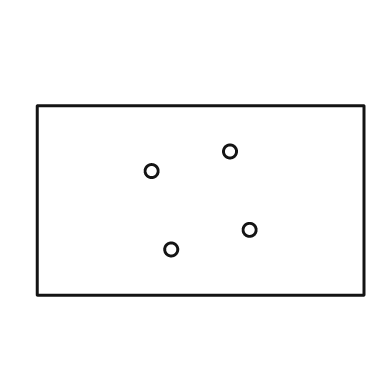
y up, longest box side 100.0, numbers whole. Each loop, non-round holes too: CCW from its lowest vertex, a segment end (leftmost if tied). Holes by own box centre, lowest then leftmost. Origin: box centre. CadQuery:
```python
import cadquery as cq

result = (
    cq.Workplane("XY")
    .moveTo(-50.0, -29.0)
    .lineTo(50.0, -29.0)
    .lineTo(50.0, 29.0)
    .lineTo(-50.0, 29.0)
    .close()
    .moveTo(-9.0, -15.0)
    .circle(2.0)
    .moveTo(15.0, -9.0)
    .circle(2.0)
    .moveTo(-15.0, 9.0)
    .circle(2.0)
    .moveTo(9.0, 15.0)
    .circle(2.0)
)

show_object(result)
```